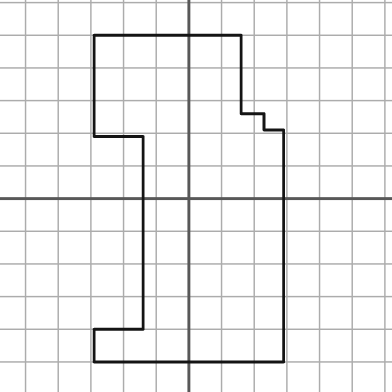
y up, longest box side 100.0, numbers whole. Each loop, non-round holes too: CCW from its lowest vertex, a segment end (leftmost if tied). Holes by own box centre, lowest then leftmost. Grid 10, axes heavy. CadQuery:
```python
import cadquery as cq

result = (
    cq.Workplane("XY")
    .moveTo(-29.0, -50.0)
    .lineTo(29.0, -50.0)
    .lineTo(29.0, 21.0)
    .lineTo(23.0, 21.0)
    .lineTo(23.0, 26.0)
    .lineTo(16.0, 26.0)
    .lineTo(16.0, 50.0)
    .lineTo(-29.0, 50.0)
    .lineTo(-29.0, 19.0)
    .lineTo(-14.0, 19.0)
    .lineTo(-14.0, -40.0)
    .lineTo(-29.0, -40.0)
    .close()
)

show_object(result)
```